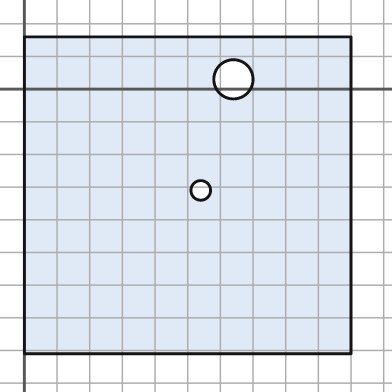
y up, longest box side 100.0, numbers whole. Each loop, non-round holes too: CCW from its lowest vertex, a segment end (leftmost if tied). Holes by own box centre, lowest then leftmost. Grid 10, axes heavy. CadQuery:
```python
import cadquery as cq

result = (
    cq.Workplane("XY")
    .moveTo(0.0, -81.0)
    .lineTo(100.0, -81.0)
    .lineTo(100.0, 16.0)
    .lineTo(0.0, 16.0)
    .close()
    .moveTo(54.0, -31.0)
    .circle(3.0)
    .moveTo(64.0, 3.0)
    .circle(6.0)
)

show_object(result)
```